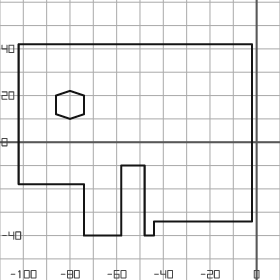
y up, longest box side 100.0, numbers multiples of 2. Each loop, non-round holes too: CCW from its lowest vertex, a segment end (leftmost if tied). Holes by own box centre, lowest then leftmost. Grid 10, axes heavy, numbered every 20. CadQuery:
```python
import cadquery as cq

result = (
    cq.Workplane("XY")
    .moveTo(-74.0, -40.0)
    .lineTo(-58.0, -40.0)
    .lineTo(-58.0, -10.0)
    .lineTo(-48.0, -10.0)
    .lineTo(-48.0, -40.0)
    .lineTo(-44.0, -40.0)
    .lineTo(-44.0, -34.0)
    .lineTo(-2.0, -34.0)
    .lineTo(-2.0, 42.0)
    .lineTo(-102.0, 42.0)
    .lineTo(-102.0, -18.0)
    .lineTo(-74.0, -18.0)
    .close()
    .moveTo(-80.0, 10.0)
    .lineTo(-74.0, 12.0)
    .lineTo(-74.0, 20.0)
    .lineTo(-80.0, 22.0)
    .lineTo(-86.0, 20.0)
    .lineTo(-86.0, 12.0)
    .close()
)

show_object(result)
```